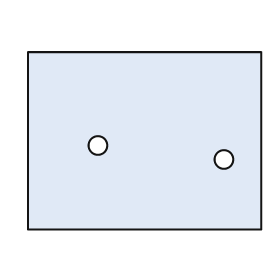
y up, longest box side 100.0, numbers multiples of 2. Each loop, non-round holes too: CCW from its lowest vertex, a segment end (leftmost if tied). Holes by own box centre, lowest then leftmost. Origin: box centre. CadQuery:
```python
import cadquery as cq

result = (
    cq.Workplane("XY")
    .moveTo(-50.0, -38.0)
    .lineTo(50.0, -38.0)
    .lineTo(50.0, 38.0)
    .lineTo(-50.0, 38.0)
    .close()
    .moveTo(34.0, -8.0)
    .circle(4.0)
    .moveTo(-20.0, -2.0)
    .circle(4.0)
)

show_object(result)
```